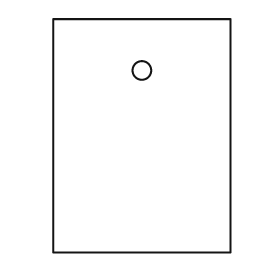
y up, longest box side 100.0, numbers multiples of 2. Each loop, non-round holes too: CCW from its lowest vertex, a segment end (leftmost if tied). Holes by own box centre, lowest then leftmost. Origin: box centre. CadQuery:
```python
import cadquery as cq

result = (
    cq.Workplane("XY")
    .moveTo(-38.0, -50.0)
    .lineTo(38.0, -50.0)
    .lineTo(38.0, 50.0)
    .lineTo(-38.0, 50.0)
    .close()
    .moveTo(0.0, 28.0)
    .circle(4.0)
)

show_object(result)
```